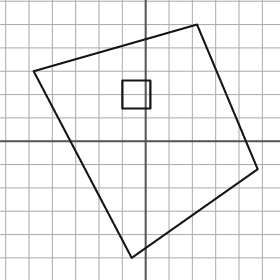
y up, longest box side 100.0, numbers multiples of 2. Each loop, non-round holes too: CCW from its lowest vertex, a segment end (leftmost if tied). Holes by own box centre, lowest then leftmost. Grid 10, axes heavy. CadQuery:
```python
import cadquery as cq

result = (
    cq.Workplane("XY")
    .moveTo(-6.0, -50.0)
    .lineTo(48.0, -12.0)
    .lineTo(22.0, 50.0)
    .lineTo(-48.0, 30.0)
    .close()
    .moveTo(-10.0, 14.0)
    .lineTo(2.0, 14.0)
    .lineTo(2.0, 26.0)
    .lineTo(-10.0, 26.0)
    .close()
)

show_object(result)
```